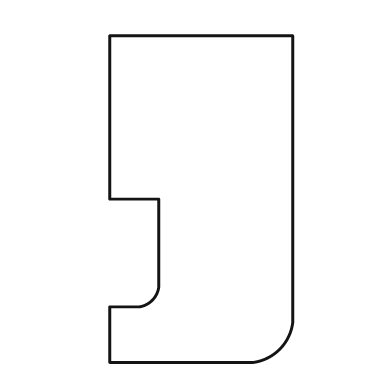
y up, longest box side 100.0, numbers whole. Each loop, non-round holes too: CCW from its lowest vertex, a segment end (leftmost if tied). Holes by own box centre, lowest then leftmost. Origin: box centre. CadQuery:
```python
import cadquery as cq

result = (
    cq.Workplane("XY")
    .moveTo(-28.0, -50.0)
    .lineTo(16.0, -50.0)
    .threePointArc((24.0, -46.0), (28.0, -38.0))
    .lineTo(28.0, 50.0)
    .lineTo(-28.0, 50.0)
    .lineTo(-28.0, 0.0)
    .lineTo(-13.0, 0.0)
    .lineTo(-13.0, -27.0)
    .threePointArc((-15.0, -31.0), (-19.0, -33.0))
    .lineTo(-28.0, -33.0)
    .close()
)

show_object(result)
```